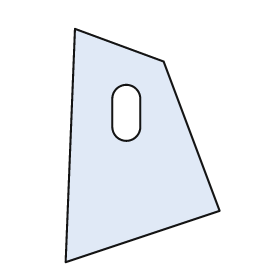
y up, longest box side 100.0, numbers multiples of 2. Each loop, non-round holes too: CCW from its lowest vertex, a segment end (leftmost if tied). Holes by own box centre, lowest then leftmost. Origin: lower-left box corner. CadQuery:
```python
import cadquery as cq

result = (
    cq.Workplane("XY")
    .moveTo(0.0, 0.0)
    .lineTo(66.0, 22.0)
    .lineTo(42.0, 86.0)
    .lineTo(4.0, 100.0)
    .close()
    .moveTo(20.0, 58.0)
    .threePointArc((26.0, 52.0), (32.0, 58.0))
    .lineTo(32.0, 70.0)
    .threePointArc((26.0, 76.0), (20.0, 70.0))
    .close()
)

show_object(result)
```